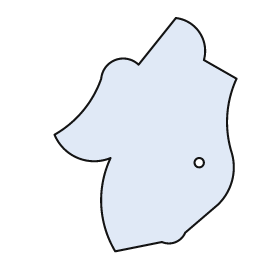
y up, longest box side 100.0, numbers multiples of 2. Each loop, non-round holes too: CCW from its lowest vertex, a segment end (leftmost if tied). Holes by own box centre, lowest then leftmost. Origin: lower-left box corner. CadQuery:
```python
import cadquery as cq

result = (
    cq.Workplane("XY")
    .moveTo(26.0, 0.0)
    .lineTo(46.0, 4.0)
    .threePointArc((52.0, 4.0), (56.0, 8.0))
    .lineTo(70.0, 20.0)
    .threePointArc((76.0, 30.0), (76.0, 42.0))
    .threePointArc((74.0, 58.0), (78.0, 74.0))
    .lineTo(64.0, 82.0)
    .threePointArc((62.0, 94.0), (52.0, 100.0))
    .lineTo(36.0, 80.0)
    .threePointArc((26.0, 82.0), (20.0, 74.0))
    .threePointArc((12.0, 60.0), (0.0, 50.0))
    .threePointArc((10.0, 40.0), (24.0, 40.0))
    .threePointArc((20.0, 20.0), (26.0, 0.0))
    .close()
    .moveTo(62.0, 38.0)
    .circle(2.0)
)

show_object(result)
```